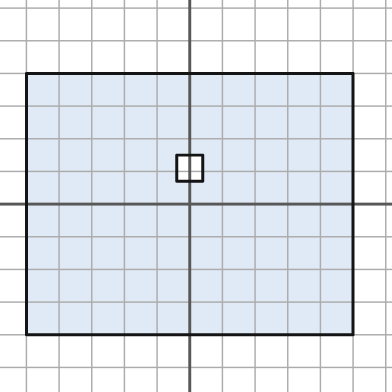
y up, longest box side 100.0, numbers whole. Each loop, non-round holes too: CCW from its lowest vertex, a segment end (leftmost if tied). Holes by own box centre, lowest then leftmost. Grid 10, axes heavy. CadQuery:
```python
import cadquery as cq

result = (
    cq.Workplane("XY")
    .moveTo(-50.0, -40.0)
    .lineTo(50.0, -40.0)
    .lineTo(50.0, 40.0)
    .lineTo(-50.0, 40.0)
    .close()
    .moveTo(-4.0, 7.0)
    .lineTo(4.0, 7.0)
    .lineTo(4.0, 15.0)
    .lineTo(-4.0, 15.0)
    .close()
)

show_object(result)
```